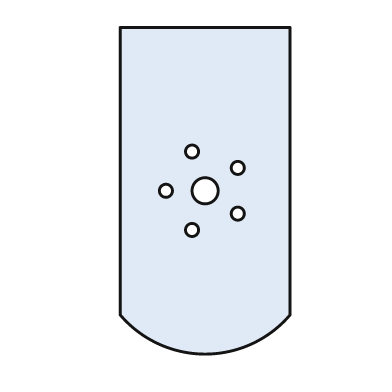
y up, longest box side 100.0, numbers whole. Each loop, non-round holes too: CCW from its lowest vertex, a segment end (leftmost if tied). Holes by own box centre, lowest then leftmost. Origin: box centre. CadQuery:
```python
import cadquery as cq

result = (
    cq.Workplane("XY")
    .moveTo(-26.0, -38.0)
    .threePointArc((0.0, -50.0), (26.0, -38.0))
    .lineTo(26.0, 50.0)
    .lineTo(-26.0, 50.0)
    .close()
    .moveTo(-4.0, -12.0)
    .circle(2.0)
    .moveTo(10.0, -7.0)
    .circle(2.0)
    .moveTo(-12.0, 0.0)
    .circle(2.0)
    .moveTo(0.0, 0.0)
    .circle(4.0)
    .moveTo(10.0, 7.0)
    .circle(2.0)
    .moveTo(-4.0, 12.0)
    .circle(2.0)
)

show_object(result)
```